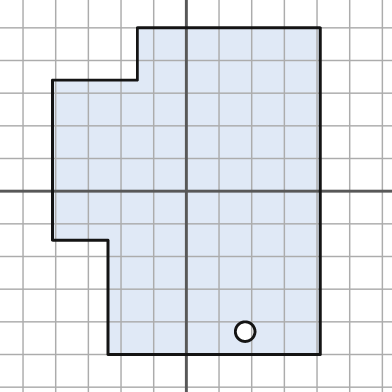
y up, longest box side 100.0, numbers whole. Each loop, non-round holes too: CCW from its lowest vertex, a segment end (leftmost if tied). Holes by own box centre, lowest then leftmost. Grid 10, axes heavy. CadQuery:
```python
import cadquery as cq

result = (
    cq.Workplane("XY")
    .moveTo(-24.0, -50.0)
    .lineTo(41.0, -50.0)
    .lineTo(41.0, 50.0)
    .lineTo(-15.0, 50.0)
    .lineTo(-15.0, 34.0)
    .lineTo(-41.0, 34.0)
    .lineTo(-41.0, -15.0)
    .lineTo(-24.0, -15.0)
    .close()
    .moveTo(18.0, -43.0)
    .circle(3.0)
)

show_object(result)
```